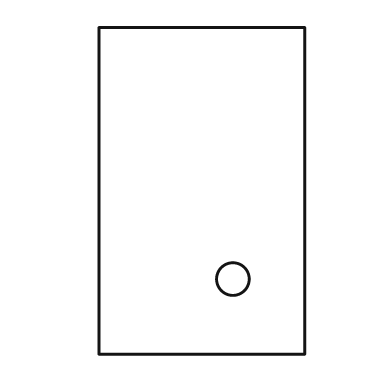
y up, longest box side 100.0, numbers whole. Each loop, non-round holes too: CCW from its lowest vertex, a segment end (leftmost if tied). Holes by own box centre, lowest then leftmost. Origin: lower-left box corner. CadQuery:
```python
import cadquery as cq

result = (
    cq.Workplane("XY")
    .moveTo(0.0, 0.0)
    .lineTo(63.0, 0.0)
    .lineTo(63.0, 100.0)
    .lineTo(0.0, 100.0)
    .close()
    .moveTo(41.0, 23.0)
    .circle(5.0)
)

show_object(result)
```